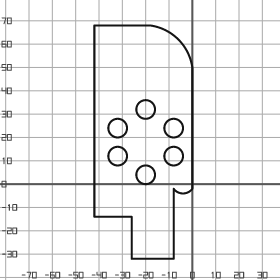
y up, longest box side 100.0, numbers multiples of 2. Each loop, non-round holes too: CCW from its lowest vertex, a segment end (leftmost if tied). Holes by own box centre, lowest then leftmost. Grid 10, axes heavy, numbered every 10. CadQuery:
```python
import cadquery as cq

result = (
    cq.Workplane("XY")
    .moveTo(-26.0, -32.0)
    .lineTo(-8.0, -32.0)
    .lineTo(-8.0, -2.0)
    .threePointArc((-4.0, -4.0), (0.0, -2.0))
    .lineTo(0.0, 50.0)
    .threePointArc((-6.0, 62.0), (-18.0, 68.0))
    .lineTo(-42.0, 68.0)
    .lineTo(-42.0, -14.0)
    .lineTo(-26.0, -14.0)
    .close()
    .moveTo(-20.0, 4.0)
    .circle(4.0)
    .moveTo(-32.0, 12.0)
    .circle(4.0)
    .moveTo(-8.0, 12.0)
    .circle(4.0)
    .moveTo(-32.0, 24.0)
    .circle(4.0)
    .moveTo(-8.0, 24.0)
    .circle(4.0)
    .moveTo(-20.0, 32.0)
    .circle(4.0)
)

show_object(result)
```